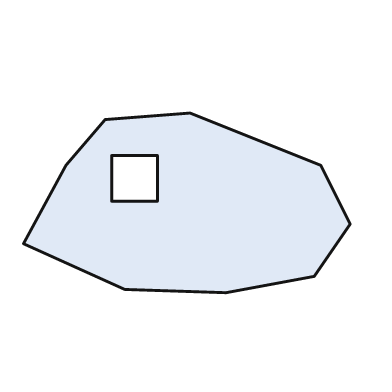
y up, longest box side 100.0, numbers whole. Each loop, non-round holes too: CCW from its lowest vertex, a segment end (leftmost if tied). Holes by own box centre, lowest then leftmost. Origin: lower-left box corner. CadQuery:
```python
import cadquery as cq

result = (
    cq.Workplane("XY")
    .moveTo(62.0, 0.0)
    .lineTo(89.0, 5.0)
    .lineTo(100.0, 21.0)
    .lineTo(91.0, 39.0)
    .lineTo(51.0, 55.0)
    .lineTo(25.0, 53.0)
    .lineTo(13.0, 39.0)
    .lineTo(0.0, 15.0)
    .lineTo(31.0, 1.0)
    .close()
    .moveTo(27.0, 28.0)
    .lineTo(41.0, 28.0)
    .lineTo(41.0, 42.0)
    .lineTo(27.0, 42.0)
    .close()
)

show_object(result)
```